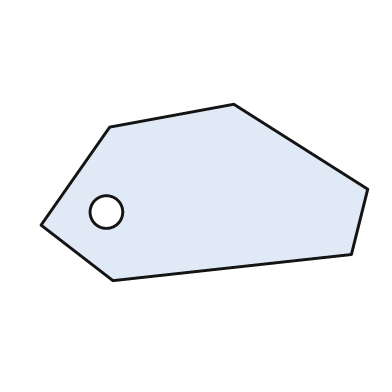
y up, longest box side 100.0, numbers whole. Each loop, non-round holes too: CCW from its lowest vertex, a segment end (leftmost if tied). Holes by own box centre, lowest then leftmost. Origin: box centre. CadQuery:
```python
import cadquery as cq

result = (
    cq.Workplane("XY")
    .moveTo(-28.0, -27.0)
    .lineTo(45.0, -19.0)
    .lineTo(50.0, 1.0)
    .lineTo(9.0, 27.0)
    .lineTo(-29.0, 20.0)
    .lineTo(-50.0, -10.0)
    .close()
    .moveTo(-30.0, -6.0)
    .circle(5.0)
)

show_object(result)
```